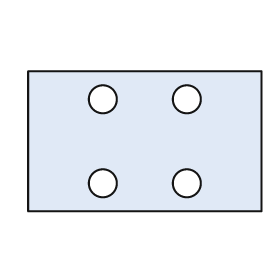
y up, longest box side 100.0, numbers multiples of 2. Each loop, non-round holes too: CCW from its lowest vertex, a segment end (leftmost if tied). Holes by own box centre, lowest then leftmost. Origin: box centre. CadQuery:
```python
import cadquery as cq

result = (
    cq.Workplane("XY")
    .moveTo(-50.0, -30.0)
    .lineTo(50.0, -30.0)
    .lineTo(50.0, 30.0)
    .lineTo(-50.0, 30.0)
    .close()
    .moveTo(-18.0, -18.0)
    .circle(6.0)
    .moveTo(18.0, -18.0)
    .circle(6.0)
    .moveTo(-18.0, 18.0)
    .circle(6.0)
    .moveTo(18.0, 18.0)
    .circle(6.0)
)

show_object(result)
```